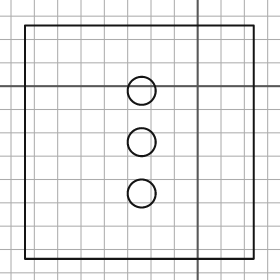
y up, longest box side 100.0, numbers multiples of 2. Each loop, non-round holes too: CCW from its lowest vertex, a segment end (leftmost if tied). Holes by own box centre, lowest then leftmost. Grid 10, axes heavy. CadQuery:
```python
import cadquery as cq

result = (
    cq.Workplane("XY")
    .moveTo(-74.0, -74.0)
    .lineTo(24.0, -74.0)
    .lineTo(24.0, 26.0)
    .lineTo(-74.0, 26.0)
    .close()
    .moveTo(-24.0, -46.0)
    .circle(6.0)
    .moveTo(-24.0, -24.0)
    .circle(6.0)
    .moveTo(-24.0, -2.0)
    .circle(6.0)
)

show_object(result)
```